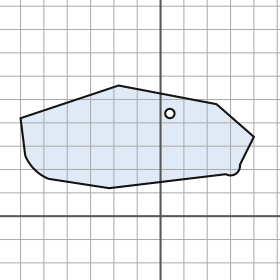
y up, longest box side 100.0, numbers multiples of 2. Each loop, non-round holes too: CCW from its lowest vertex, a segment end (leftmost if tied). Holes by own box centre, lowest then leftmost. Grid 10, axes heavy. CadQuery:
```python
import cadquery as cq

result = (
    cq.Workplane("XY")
    .moveTo(-22.0, 12.0)
    .lineTo(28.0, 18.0)
    .threePointArc((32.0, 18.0), (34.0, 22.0))
    .lineTo(40.0, 34.0)
    .lineTo(24.0, 48.0)
    .lineTo(-18.0, 56.0)
    .lineTo(-60.0, 42.0)
    .lineTo(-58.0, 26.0)
    .threePointArc((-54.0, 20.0), (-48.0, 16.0))
    .close()
    .moveTo(4.0, 44.0)
    .circle(2.0)
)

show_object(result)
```